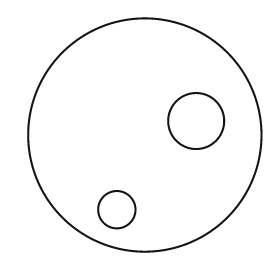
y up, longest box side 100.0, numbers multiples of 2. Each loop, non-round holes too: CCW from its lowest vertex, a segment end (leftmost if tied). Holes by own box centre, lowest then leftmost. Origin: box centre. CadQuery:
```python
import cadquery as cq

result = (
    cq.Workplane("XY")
    .moveTo(0.0, 0.0)
    .circle(50.0)
    .moveTo(-12.0, -32.0)
    .circle(8.0)
    .moveTo(22.0, 6.0)
    .circle(12.0)
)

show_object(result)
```